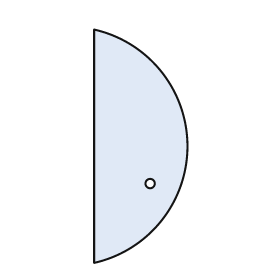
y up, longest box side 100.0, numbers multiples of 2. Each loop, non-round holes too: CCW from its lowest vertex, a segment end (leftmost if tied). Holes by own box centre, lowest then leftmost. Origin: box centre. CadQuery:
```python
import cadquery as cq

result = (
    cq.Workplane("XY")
    .moveTo(-20.0, -50.0)
    .threePointArc((20.0, 0.0), (-20.0, 50.0))
    .close()
    .moveTo(4.0, -16.0)
    .circle(2.0)
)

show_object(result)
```